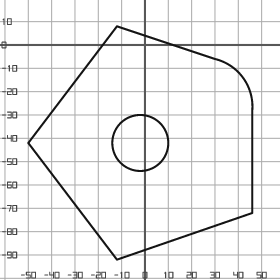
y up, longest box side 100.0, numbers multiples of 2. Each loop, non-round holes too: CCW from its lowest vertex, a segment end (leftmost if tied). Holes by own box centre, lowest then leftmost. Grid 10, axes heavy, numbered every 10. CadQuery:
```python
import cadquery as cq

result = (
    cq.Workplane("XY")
    .moveTo(-12.0, -92.0)
    .lineTo(46.0, -72.0)
    .lineTo(46.0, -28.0)
    .threePointArc((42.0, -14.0), (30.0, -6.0))
    .lineTo(-12.0, 8.0)
    .lineTo(-50.0, -42.0)
    .close()
    .moveTo(-2.0, -42.0)
    .circle(12.0)
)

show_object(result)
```